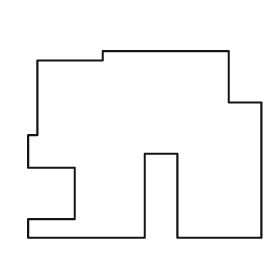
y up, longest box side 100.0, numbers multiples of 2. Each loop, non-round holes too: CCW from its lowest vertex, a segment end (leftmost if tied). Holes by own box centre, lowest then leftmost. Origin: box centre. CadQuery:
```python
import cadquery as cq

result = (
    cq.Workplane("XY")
    .moveTo(-50.0, -40.0)
    .lineTo(0.0, -40.0)
    .lineTo(0.0, -4.0)
    .lineTo(14.0, -4.0)
    .lineTo(14.0, -40.0)
    .lineTo(50.0, -40.0)
    .lineTo(50.0, 18.0)
    .lineTo(36.0, 18.0)
    .lineTo(36.0, 40.0)
    .lineTo(-18.0, 40.0)
    .lineTo(-18.0, 36.0)
    .lineTo(-46.0, 36.0)
    .lineTo(-46.0, 4.0)
    .lineTo(-50.0, 4.0)
    .lineTo(-50.0, -10.0)
    .lineTo(-30.0, -10.0)
    .lineTo(-30.0, -32.0)
    .lineTo(-50.0, -32.0)
    .close()
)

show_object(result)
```